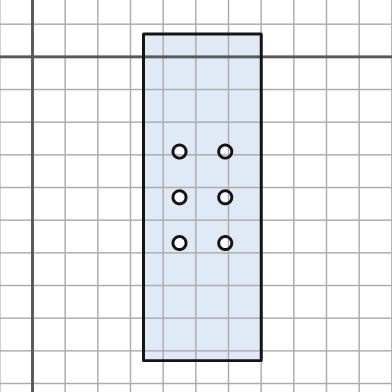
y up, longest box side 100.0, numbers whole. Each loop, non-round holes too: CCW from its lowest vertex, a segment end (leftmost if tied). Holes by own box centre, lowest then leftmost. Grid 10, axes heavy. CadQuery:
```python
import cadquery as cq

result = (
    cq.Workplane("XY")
    .moveTo(34.0, -93.0)
    .lineTo(70.0, -93.0)
    .lineTo(70.0, 7.0)
    .lineTo(34.0, 7.0)
    .close()
    .moveTo(45.0, -57.0)
    .circle(2.0)
    .moveTo(59.0, -57.0)
    .circle(2.0)
    .moveTo(45.0, -43.0)
    .circle(2.0)
    .moveTo(59.0, -43.0)
    .circle(2.0)
    .moveTo(45.0, -29.0)
    .circle(2.0)
    .moveTo(59.0, -29.0)
    .circle(2.0)
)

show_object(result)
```